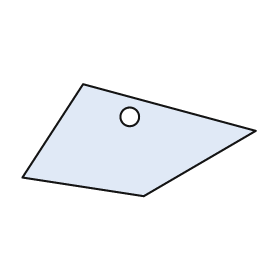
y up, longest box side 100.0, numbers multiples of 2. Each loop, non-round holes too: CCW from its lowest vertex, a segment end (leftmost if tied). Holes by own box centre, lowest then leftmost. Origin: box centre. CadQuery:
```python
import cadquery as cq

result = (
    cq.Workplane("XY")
    .moveTo(2.0, -24.0)
    .lineTo(50.0, 4.0)
    .lineTo(-24.0, 24.0)
    .lineTo(-50.0, -16.0)
    .close()
    .moveTo(-4.0, 10.0)
    .circle(4.0)
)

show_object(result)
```